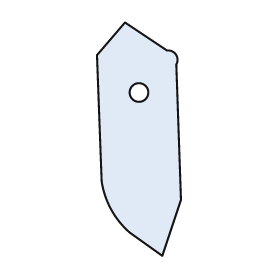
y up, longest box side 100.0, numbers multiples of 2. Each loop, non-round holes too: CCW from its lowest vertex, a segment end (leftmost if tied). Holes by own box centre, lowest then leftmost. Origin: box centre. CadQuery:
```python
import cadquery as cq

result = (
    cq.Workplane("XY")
    .moveTo(10.0, -50.0)
    .lineTo(18.0, -26.0)
    .lineTo(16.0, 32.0)
    .threePointArc((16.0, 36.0), (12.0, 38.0))
    .lineTo(-6.0, 50.0)
    .lineTo(-18.0, 36.0)
    .lineTo(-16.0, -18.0)
    .threePointArc((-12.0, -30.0), (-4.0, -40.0))
    .close()
    .moveTo(0.0, 20.0)
    .circle(4.0)
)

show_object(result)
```